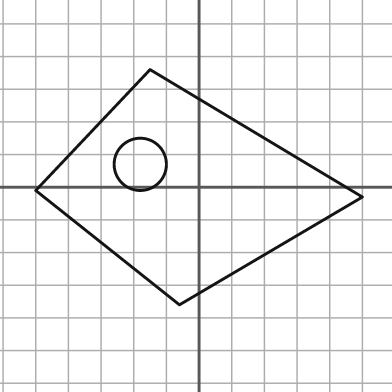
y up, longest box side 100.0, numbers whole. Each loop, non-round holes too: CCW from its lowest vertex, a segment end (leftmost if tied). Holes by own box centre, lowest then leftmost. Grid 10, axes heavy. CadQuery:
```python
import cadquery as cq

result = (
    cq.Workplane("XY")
    .moveTo(-6.0, -36.0)
    .lineTo(50.0, -3.0)
    .lineTo(-15.0, 36.0)
    .lineTo(-50.0, -1.0)
    .close()
    .moveTo(-18.0, 7.0)
    .circle(8.0)
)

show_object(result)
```